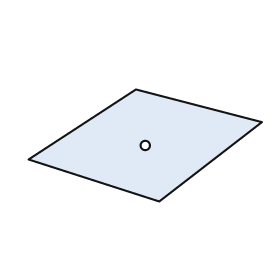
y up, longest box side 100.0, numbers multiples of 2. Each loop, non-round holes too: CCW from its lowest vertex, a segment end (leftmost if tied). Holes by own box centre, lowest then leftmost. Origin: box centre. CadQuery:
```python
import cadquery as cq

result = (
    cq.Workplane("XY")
    .moveTo(6.0, -24.0)
    .lineTo(50.0, 10.0)
    .lineTo(-4.0, 24.0)
    .lineTo(-50.0, -6.0)
    .close()
    .moveTo(0.0, 0.0)
    .circle(2.0)
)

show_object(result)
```